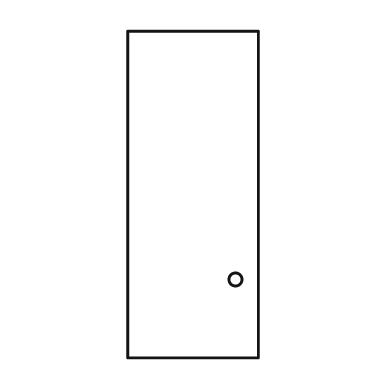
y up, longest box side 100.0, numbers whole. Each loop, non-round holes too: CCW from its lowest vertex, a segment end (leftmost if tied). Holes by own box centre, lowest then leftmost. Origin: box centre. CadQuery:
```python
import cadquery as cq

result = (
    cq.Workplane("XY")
    .moveTo(-20.0, -50.0)
    .lineTo(20.0, -50.0)
    .lineTo(20.0, 50.0)
    .lineTo(-20.0, 50.0)
    .close()
    .moveTo(13.0, -26.0)
    .circle(2.0)
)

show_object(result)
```